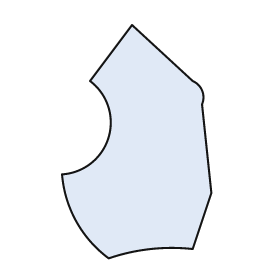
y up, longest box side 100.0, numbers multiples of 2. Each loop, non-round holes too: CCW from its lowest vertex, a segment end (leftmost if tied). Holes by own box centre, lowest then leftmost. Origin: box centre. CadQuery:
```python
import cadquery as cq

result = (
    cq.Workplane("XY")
    .moveTo(-12.0, -50.0)
    .threePointArc((6.0, -46.0), (24.0, -46.0))
    .lineTo(32.0, -22.0)
    .lineTo(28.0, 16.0)
    .threePointArc((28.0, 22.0), (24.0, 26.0))
    .lineTo(-2.0, 50.0)
    .lineTo(-20.0, 26.0)
    .threePointArc((-12.0, 2.0), (-32.0, -14.0))
    .threePointArc((-26.0, -34.0), (-12.0, -50.0))
    .close()
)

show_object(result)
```